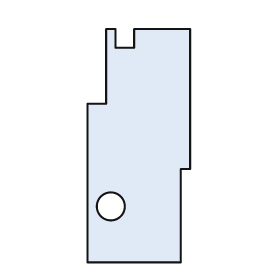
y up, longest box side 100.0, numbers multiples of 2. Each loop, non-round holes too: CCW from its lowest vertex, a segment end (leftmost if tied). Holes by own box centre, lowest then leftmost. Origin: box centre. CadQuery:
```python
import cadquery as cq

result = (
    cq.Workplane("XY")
    .moveTo(-22.0, -50.0)
    .lineTo(18.0, -50.0)
    .lineTo(18.0, -10.0)
    .lineTo(22.0, -10.0)
    .lineTo(22.0, 50.0)
    .lineTo(-2.0, 50.0)
    .lineTo(-2.0, 42.0)
    .lineTo(-10.0, 42.0)
    .lineTo(-10.0, 50.0)
    .lineTo(-14.0, 50.0)
    .lineTo(-14.0, 18.0)
    .lineTo(-22.0, 18.0)
    .close()
    .moveTo(-12.0, -26.0)
    .circle(6.0)
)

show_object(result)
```